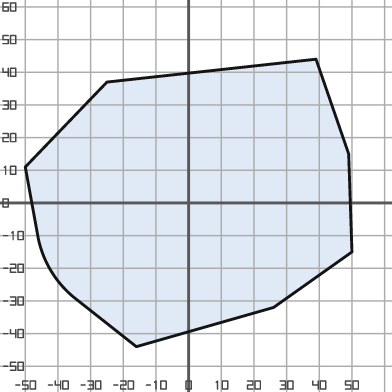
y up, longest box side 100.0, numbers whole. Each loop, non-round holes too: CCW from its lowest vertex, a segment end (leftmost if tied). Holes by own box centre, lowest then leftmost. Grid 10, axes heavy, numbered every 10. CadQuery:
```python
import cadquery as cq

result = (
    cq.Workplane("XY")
    .moveTo(-16.0, -44.0)
    .lineTo(26.0, -32.0)
    .lineTo(50.0, -15.0)
    .lineTo(49.0, 15.0)
    .lineTo(39.0, 44.0)
    .lineTo(-25.0, 37.0)
    .lineTo(-50.0, 11.0)
    .lineTo(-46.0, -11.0)
    .threePointArc((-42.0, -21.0), (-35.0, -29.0))
    .close()
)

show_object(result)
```